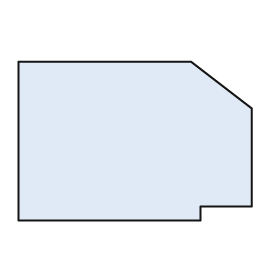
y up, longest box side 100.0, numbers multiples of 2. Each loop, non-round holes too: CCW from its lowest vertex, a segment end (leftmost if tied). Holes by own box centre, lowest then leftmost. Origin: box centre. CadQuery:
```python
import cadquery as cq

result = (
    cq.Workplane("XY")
    .moveTo(-50.0, -34.0)
    .lineTo(28.0, -34.0)
    .lineTo(28.0, -28.0)
    .lineTo(50.0, -28.0)
    .lineTo(50.0, 14.0)
    .lineTo(24.0, 34.0)
    .lineTo(-50.0, 34.0)
    .close()
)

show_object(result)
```